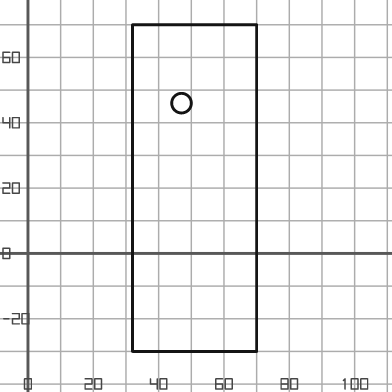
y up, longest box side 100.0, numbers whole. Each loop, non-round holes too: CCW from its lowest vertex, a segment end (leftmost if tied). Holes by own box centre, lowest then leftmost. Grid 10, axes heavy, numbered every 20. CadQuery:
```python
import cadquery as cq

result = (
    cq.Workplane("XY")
    .moveTo(32.0, -30.0)
    .lineTo(70.0, -30.0)
    .lineTo(70.0, 70.0)
    .lineTo(32.0, 70.0)
    .close()
    .moveTo(47.0, 46.0)
    .circle(3.0)
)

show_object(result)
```